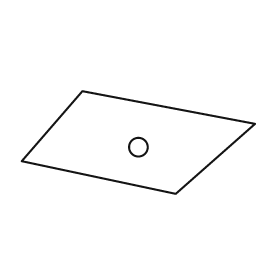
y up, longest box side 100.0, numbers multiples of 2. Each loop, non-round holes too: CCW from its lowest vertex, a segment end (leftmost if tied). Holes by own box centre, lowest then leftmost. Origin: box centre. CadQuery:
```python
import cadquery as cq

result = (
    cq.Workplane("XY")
    .moveTo(16.0, -22.0)
    .lineTo(50.0, 8.0)
    .lineTo(-24.0, 22.0)
    .lineTo(-50.0, -8.0)
    .close()
    .moveTo(0.0, -2.0)
    .circle(4.0)
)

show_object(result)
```